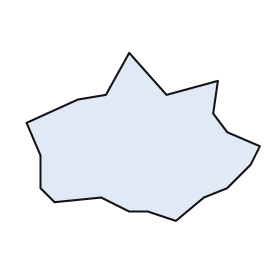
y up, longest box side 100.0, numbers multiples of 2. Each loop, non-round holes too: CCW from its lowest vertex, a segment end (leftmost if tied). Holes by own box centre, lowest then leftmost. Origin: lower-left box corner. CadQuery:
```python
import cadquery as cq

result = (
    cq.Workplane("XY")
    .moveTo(64.0, 0.0)
    .lineTo(76.0, 10.0)
    .lineTo(86.0, 14.0)
    .lineTo(96.0, 24.0)
    .lineTo(100.0, 32.0)
    .lineTo(86.0, 38.0)
    .lineTo(80.0, 46.0)
    .lineTo(82.0, 60.0)
    .lineTo(60.0, 54.0)
    .lineTo(44.0, 72.0)
    .lineTo(34.0, 54.0)
    .lineTo(22.0, 52.0)
    .lineTo(0.0, 42.0)
    .lineTo(6.0, 28.0)
    .lineTo(6.0, 14.0)
    .lineTo(12.0, 8.0)
    .lineTo(32.0, 10.0)
    .lineTo(44.0, 4.0)
    .lineTo(52.0, 4.0)
    .close()
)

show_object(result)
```